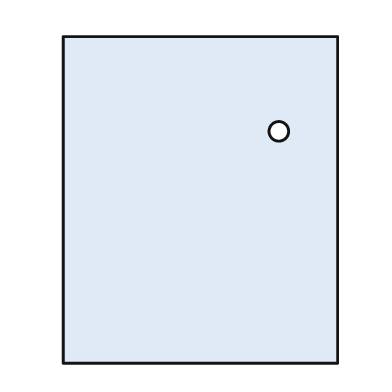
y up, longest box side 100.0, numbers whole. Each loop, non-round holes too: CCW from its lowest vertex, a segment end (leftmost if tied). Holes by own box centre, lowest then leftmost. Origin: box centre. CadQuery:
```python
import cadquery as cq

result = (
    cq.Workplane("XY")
    .moveTo(-42.0, -50.0)
    .lineTo(42.0, -50.0)
    .lineTo(42.0, 50.0)
    .lineTo(-42.0, 50.0)
    .close()
    .moveTo(24.0, 21.0)
    .circle(3.0)
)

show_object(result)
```